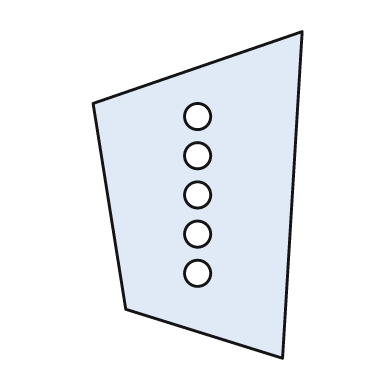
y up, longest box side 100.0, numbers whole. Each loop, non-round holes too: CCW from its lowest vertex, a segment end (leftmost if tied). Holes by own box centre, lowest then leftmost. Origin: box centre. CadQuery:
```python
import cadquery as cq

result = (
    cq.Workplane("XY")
    .moveTo(26.0, -50.0)
    .lineTo(32.0, 50.0)
    .lineTo(-32.0, 28.0)
    .lineTo(-22.0, -35.0)
    .close()
    .moveTo(0.0, -24.0)
    .circle(4.0)
    .moveTo(0.0, -12.0)
    .circle(4.0)
    .moveTo(0.0, 0.0)
    .circle(4.0)
    .moveTo(0.0, 12.0)
    .circle(4.0)
    .moveTo(0.0, 24.0)
    .circle(4.0)
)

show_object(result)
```